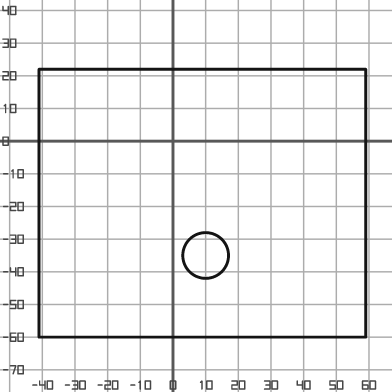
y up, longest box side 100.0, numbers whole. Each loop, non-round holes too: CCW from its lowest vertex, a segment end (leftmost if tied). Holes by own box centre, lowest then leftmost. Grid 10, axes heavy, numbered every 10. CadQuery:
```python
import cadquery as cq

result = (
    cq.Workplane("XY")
    .moveTo(-41.0, -60.0)
    .lineTo(59.0, -60.0)
    .lineTo(59.0, 22.0)
    .lineTo(-41.0, 22.0)
    .close()
    .moveTo(10.0, -35.0)
    .circle(7.0)
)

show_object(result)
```